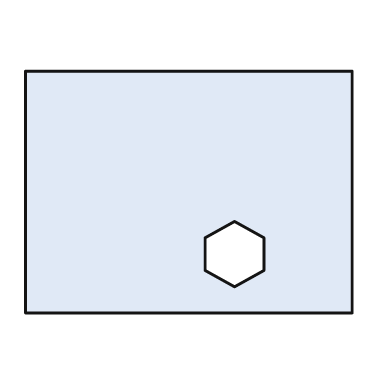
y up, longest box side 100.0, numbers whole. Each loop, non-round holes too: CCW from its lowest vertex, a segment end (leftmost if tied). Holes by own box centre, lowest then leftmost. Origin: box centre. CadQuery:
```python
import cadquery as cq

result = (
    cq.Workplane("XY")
    .moveTo(-50.0, -37.0)
    .lineTo(50.0, -37.0)
    .lineTo(50.0, 37.0)
    .lineTo(-50.0, 37.0)
    .close()
    .moveTo(14.0, -29.0)
    .lineTo(23.0, -24.0)
    .lineTo(23.0, -14.0)
    .lineTo(14.0, -9.0)
    .lineTo(5.0, -14.0)
    .lineTo(5.0, -24.0)
    .close()
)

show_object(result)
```